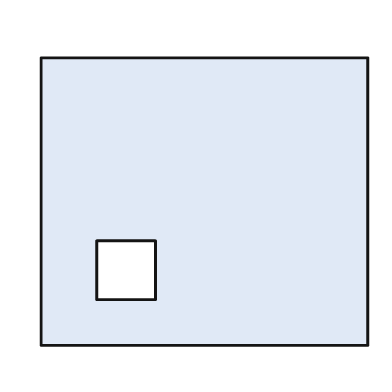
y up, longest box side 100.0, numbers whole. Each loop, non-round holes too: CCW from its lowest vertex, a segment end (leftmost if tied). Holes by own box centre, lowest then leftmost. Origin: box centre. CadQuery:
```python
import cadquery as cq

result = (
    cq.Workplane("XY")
    .moveTo(-50.0, -44.0)
    .lineTo(50.0, -44.0)
    .lineTo(50.0, 44.0)
    .lineTo(-50.0, 44.0)
    .close()
    .moveTo(-33.0, -30.0)
    .lineTo(-15.0, -30.0)
    .lineTo(-15.0, -12.0)
    .lineTo(-33.0, -12.0)
    .close()
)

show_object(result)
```